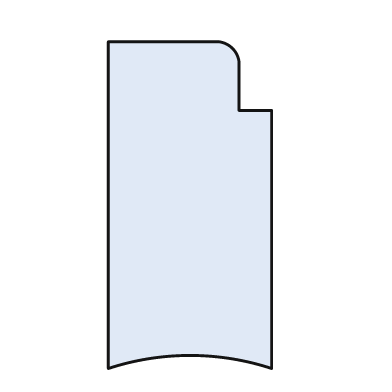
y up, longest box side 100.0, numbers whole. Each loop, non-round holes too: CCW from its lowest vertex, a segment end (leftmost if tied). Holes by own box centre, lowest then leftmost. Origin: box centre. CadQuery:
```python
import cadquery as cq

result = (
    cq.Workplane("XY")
    .moveTo(-25.0, -50.0)
    .threePointArc((0.0, -46.0), (25.0, -50.0))
    .lineTo(25.0, 29.0)
    .lineTo(15.0, 29.0)
    .lineTo(15.0, 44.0)
    .threePointArc((13.0, 48.0), (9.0, 50.0))
    .lineTo(-25.0, 50.0)
    .close()
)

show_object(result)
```